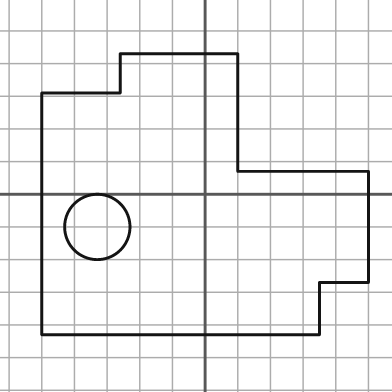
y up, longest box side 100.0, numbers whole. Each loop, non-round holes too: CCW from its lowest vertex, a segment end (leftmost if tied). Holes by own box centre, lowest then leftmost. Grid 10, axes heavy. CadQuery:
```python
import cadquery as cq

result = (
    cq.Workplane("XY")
    .moveTo(-50.0, -43.0)
    .lineTo(35.0, -43.0)
    .lineTo(35.0, -27.0)
    .lineTo(50.0, -27.0)
    .lineTo(50.0, 7.0)
    .lineTo(10.0, 7.0)
    .lineTo(10.0, 43.0)
    .lineTo(-26.0, 43.0)
    .lineTo(-26.0, 31.0)
    .lineTo(-50.0, 31.0)
    .close()
    .moveTo(-33.0, -10.0)
    .circle(10.0)
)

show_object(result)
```